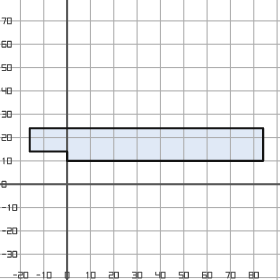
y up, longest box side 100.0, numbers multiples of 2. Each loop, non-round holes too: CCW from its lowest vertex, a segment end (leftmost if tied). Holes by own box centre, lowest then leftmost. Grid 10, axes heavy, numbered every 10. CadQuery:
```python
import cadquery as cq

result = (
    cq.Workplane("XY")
    .moveTo(0.0, 10.0)
    .lineTo(84.0, 10.0)
    .lineTo(84.0, 24.0)
    .lineTo(-16.0, 24.0)
    .lineTo(-16.0, 14.0)
    .lineTo(0.0, 14.0)
    .close()
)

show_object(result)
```